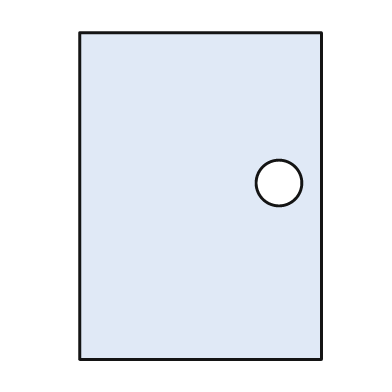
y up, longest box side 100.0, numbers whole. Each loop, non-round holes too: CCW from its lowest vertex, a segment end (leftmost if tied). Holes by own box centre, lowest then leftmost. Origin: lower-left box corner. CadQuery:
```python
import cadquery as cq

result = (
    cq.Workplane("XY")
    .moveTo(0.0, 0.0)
    .lineTo(74.0, 0.0)
    .lineTo(74.0, 100.0)
    .lineTo(0.0, 100.0)
    .close()
    .moveTo(61.0, 54.0)
    .circle(7.0)
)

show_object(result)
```